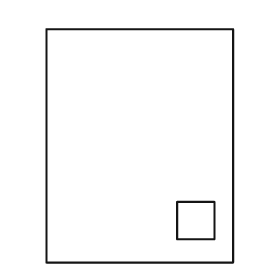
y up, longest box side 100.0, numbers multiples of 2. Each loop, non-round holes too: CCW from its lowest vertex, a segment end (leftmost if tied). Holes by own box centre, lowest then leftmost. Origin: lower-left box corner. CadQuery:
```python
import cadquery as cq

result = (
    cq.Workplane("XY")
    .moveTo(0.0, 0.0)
    .lineTo(80.0, 0.0)
    .lineTo(80.0, 100.0)
    .lineTo(0.0, 100.0)
    .close()
    .moveTo(56.0, 10.0)
    .lineTo(72.0, 10.0)
    .lineTo(72.0, 26.0)
    .lineTo(56.0, 26.0)
    .close()
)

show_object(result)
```